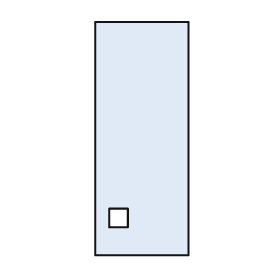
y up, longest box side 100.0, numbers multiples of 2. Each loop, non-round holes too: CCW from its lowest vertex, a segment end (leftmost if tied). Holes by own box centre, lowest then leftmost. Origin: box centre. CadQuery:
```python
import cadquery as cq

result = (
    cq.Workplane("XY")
    .moveTo(-20.0, -50.0)
    .lineTo(20.0, -50.0)
    .lineTo(20.0, 50.0)
    .lineTo(-20.0, 50.0)
    .close()
    .moveTo(-14.0, -38.0)
    .lineTo(-6.0, -38.0)
    .lineTo(-6.0, -30.0)
    .lineTo(-14.0, -30.0)
    .close()
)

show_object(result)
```